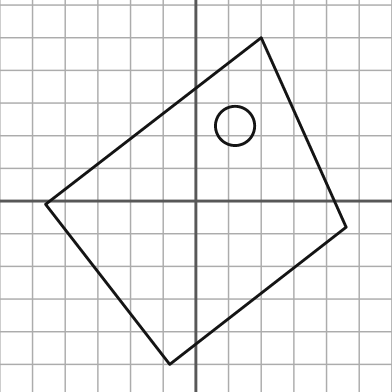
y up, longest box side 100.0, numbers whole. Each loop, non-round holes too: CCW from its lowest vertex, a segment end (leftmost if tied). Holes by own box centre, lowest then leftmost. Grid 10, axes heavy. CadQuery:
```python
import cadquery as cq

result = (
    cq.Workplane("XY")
    .moveTo(-8.0, -50.0)
    .lineTo(46.0, -8.0)
    .lineTo(20.0, 50.0)
    .lineTo(-46.0, -1.0)
    .close()
    .moveTo(12.0, 23.0)
    .circle(6.0)
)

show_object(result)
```